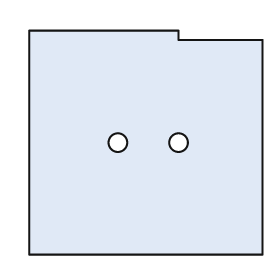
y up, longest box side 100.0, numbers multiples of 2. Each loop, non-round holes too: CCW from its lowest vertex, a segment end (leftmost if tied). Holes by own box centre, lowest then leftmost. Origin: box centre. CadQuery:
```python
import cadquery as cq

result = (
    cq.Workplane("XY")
    .moveTo(-50.0, -48.0)
    .lineTo(50.0, -48.0)
    .lineTo(50.0, 44.0)
    .lineTo(14.0, 44.0)
    .lineTo(14.0, 48.0)
    .lineTo(-50.0, 48.0)
    .close()
    .moveTo(-12.0, 0.0)
    .circle(4.0)
    .moveTo(14.0, 0.0)
    .circle(4.0)
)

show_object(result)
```